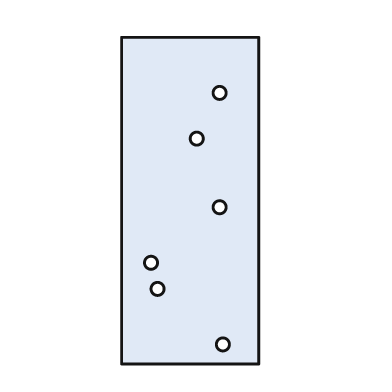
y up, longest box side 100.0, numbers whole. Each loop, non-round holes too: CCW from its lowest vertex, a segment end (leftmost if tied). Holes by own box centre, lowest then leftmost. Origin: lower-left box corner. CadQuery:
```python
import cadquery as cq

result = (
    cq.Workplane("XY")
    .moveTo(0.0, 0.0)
    .lineTo(42.0, 0.0)
    .lineTo(42.0, 100.0)
    .lineTo(0.0, 100.0)
    .close()
    .moveTo(31.0, 6.0)
    .circle(2.0)
    .moveTo(11.0, 23.0)
    .circle(2.0)
    .moveTo(9.0, 31.0)
    .circle(2.0)
    .moveTo(30.0, 48.0)
    .circle(2.0)
    .moveTo(23.0, 69.0)
    .circle(2.0)
    .moveTo(30.0, 83.0)
    .circle(2.0)
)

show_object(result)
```